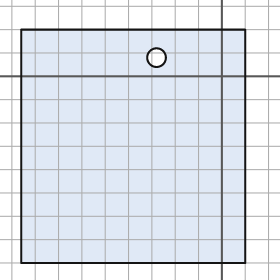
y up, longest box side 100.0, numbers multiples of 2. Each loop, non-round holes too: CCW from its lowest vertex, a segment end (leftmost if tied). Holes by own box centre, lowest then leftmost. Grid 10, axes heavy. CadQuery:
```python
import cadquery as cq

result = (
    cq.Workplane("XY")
    .moveTo(-86.0, -80.0)
    .lineTo(10.0, -80.0)
    .lineTo(10.0, 20.0)
    .lineTo(-86.0, 20.0)
    .close()
    .moveTo(-28.0, 8.0)
    .circle(4.0)
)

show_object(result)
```